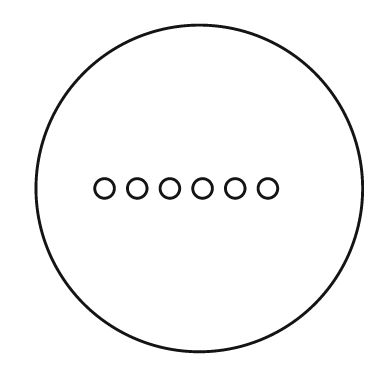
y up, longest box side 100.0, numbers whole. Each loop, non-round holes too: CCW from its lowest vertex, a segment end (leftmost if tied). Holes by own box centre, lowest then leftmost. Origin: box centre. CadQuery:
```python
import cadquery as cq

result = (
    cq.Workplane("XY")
    .moveTo(0.0, 0.0)
    .circle(50.0)
    .moveTo(-29.0, 0.0)
    .circle(3.0)
    .moveTo(-19.0, 0.0)
    .circle(3.0)
    .moveTo(-9.0, 0.0)
    .circle(3.0)
    .moveTo(1.0, 0.0)
    .circle(3.0)
    .moveTo(11.0, 0.0)
    .circle(3.0)
    .moveTo(21.0, 0.0)
    .circle(3.0)
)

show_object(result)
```